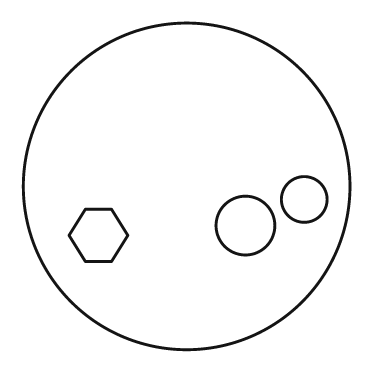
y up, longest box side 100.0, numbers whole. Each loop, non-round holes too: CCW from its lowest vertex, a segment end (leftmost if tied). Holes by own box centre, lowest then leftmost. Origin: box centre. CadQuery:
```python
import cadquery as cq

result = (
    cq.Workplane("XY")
    .moveTo(0.0, 0.0)
    .circle(50.0)
    .moveTo(-31.0, -23.0)
    .lineTo(-23.0, -23.0)
    .lineTo(-18.0, -15.0)
    .lineTo(-23.0, -7.0)
    .lineTo(-31.0, -7.0)
    .lineTo(-36.0, -15.0)
    .close()
    .moveTo(18.0, -12.0)
    .circle(9.0)
    .moveTo(36.0, -4.0)
    .circle(7.0)
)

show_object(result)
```